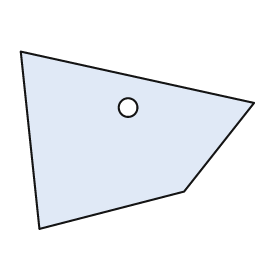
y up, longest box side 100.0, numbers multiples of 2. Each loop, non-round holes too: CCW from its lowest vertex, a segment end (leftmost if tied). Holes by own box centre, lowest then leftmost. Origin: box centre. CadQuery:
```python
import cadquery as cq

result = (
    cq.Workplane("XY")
    .moveTo(-42.0, -38.0)
    .lineTo(20.0, -22.0)
    .lineTo(50.0, 16.0)
    .lineTo(-50.0, 38.0)
    .close()
    .moveTo(-4.0, 14.0)
    .circle(4.0)
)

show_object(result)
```